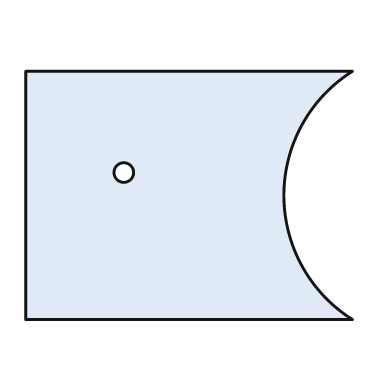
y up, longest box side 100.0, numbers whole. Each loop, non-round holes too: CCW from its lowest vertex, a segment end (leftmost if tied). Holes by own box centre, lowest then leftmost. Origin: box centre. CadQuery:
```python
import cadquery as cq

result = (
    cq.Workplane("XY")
    .moveTo(-50.0, -38.0)
    .lineTo(50.0, -38.0)
    .threePointArc((29.0, 0.0), (50.0, 38.0))
    .lineTo(-50.0, 38.0)
    .close()
    .moveTo(-20.0, 7.0)
    .circle(3.0)
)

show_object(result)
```